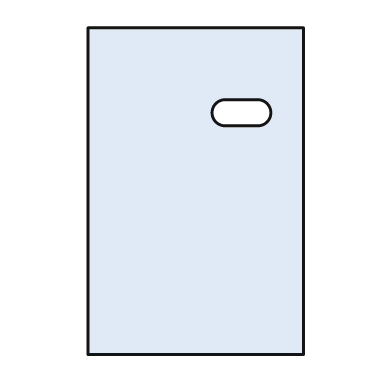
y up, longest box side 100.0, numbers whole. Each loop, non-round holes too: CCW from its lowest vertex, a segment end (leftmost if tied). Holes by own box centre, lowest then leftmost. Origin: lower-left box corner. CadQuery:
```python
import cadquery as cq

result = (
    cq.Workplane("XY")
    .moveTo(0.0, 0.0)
    .lineTo(66.0, 0.0)
    .lineTo(66.0, 100.0)
    .lineTo(0.0, 100.0)
    .close()
    .moveTo(42.0, 70.0)
    .lineTo(52.0, 70.0)
    .threePointArc((56.0, 74.0), (52.0, 78.0))
    .lineTo(42.0, 78.0)
    .threePointArc((38.0, 74.0), (42.0, 70.0))
    .close()
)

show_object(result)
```